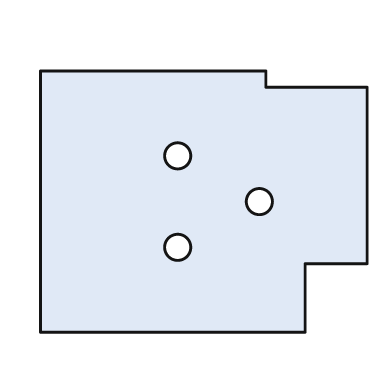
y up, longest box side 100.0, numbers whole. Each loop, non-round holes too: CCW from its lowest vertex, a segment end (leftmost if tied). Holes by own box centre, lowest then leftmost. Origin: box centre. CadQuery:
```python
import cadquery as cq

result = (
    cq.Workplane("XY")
    .moveTo(-50.0, -40.0)
    .lineTo(31.0, -40.0)
    .lineTo(31.0, -19.0)
    .lineTo(50.0, -19.0)
    .lineTo(50.0, 35.0)
    .lineTo(19.0, 35.0)
    .lineTo(19.0, 40.0)
    .lineTo(-50.0, 40.0)
    .close()
    .moveTo(-8.0, -14.0)
    .circle(4.0)
    .moveTo(17.0, 0.0)
    .circle(4.0)
    .moveTo(-8.0, 14.0)
    .circle(4.0)
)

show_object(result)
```